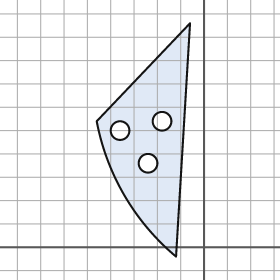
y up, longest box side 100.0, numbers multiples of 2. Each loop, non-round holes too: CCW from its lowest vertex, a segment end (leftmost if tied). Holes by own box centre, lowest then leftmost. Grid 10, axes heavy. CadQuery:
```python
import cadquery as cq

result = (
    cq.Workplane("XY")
    .moveTo(-12.0, -4.0)
    .lineTo(-6.0, 96.0)
    .lineTo(-46.0, 54.0)
    .threePointArc((-34.0, 22.0), (-12.0, -4.0))
    .close()
    .moveTo(-24.0, 36.0)
    .circle(4.0)
    .moveTo(-36.0, 50.0)
    .circle(4.0)
    .moveTo(-18.0, 54.0)
    .circle(4.0)
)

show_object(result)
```